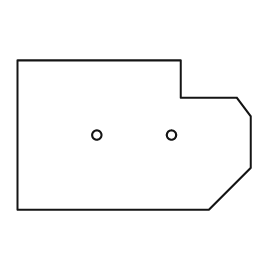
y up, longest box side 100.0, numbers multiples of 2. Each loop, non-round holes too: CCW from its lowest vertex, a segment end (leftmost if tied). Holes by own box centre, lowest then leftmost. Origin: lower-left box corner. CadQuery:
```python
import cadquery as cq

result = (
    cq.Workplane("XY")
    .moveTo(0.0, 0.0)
    .lineTo(82.0, 0.0)
    .lineTo(100.0, 18.0)
    .lineTo(100.0, 40.0)
    .lineTo(94.0, 48.0)
    .lineTo(70.0, 48.0)
    .lineTo(70.0, 64.0)
    .lineTo(0.0, 64.0)
    .close()
    .moveTo(34.0, 32.0)
    .circle(2.0)
    .moveTo(66.0, 32.0)
    .circle(2.0)
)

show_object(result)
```